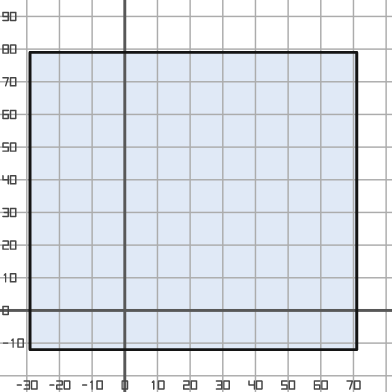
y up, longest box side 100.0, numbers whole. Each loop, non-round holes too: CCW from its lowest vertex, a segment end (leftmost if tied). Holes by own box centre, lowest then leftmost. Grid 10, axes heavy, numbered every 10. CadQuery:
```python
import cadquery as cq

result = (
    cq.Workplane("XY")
    .moveTo(-29.0, -12.0)
    .lineTo(71.0, -12.0)
    .lineTo(71.0, 79.0)
    .lineTo(-29.0, 79.0)
    .close()
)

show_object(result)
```